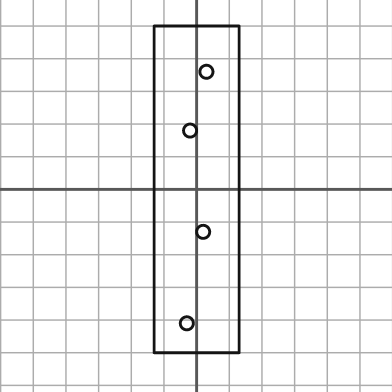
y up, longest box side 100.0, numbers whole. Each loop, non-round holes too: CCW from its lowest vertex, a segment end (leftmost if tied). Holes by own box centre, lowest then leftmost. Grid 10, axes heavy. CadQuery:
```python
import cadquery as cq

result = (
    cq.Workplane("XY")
    .moveTo(-13.0, -50.0)
    .lineTo(13.0, -50.0)
    .lineTo(13.0, 50.0)
    .lineTo(-13.0, 50.0)
    .close()
    .moveTo(-3.0, -41.0)
    .circle(2.0)
    .moveTo(2.0, -13.0)
    .circle(2.0)
    .moveTo(-2.0, 18.0)
    .circle(2.0)
    .moveTo(3.0, 36.0)
    .circle(2.0)
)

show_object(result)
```